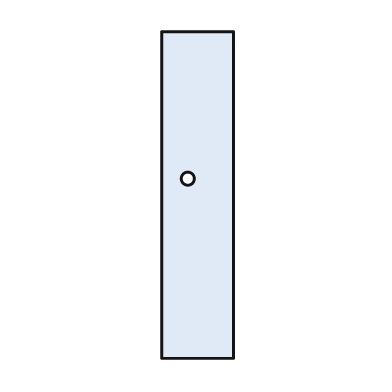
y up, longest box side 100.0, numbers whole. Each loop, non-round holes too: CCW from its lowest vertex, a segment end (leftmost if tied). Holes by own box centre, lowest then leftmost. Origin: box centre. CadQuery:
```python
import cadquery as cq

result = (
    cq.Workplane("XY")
    .moveTo(-11.0, -50.0)
    .lineTo(11.0, -50.0)
    .lineTo(11.0, 50.0)
    .lineTo(-11.0, 50.0)
    .close()
    .moveTo(-3.0, 5.0)
    .circle(2.0)
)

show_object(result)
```